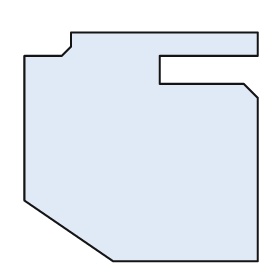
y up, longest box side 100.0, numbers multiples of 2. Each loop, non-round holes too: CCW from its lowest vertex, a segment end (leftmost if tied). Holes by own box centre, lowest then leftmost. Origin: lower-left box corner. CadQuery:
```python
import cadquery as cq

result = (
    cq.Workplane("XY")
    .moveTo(38.0, 0.0)
    .lineTo(100.0, 0.0)
    .lineTo(100.0, 70.0)
    .lineTo(94.0, 76.0)
    .lineTo(58.0, 76.0)
    .lineTo(58.0, 88.0)
    .lineTo(100.0, 88.0)
    .lineTo(100.0, 98.0)
    .lineTo(20.0, 98.0)
    .lineTo(20.0, 92.0)
    .lineTo(16.0, 88.0)
    .lineTo(0.0, 88.0)
    .lineTo(0.0, 26.0)
    .close()
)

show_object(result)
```